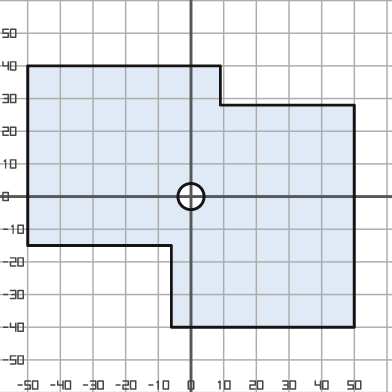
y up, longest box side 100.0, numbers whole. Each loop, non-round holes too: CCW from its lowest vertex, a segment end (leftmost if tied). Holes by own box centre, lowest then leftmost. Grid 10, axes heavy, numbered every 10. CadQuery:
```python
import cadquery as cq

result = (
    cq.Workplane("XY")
    .moveTo(-6.0, -40.0)
    .lineTo(50.0, -40.0)
    .lineTo(50.0, 28.0)
    .lineTo(9.0, 28.0)
    .lineTo(9.0, 40.0)
    .lineTo(-50.0, 40.0)
    .lineTo(-50.0, -15.0)
    .lineTo(-6.0, -15.0)
    .close()
    .moveTo(0.0, 0.0)
    .circle(4.0)
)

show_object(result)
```